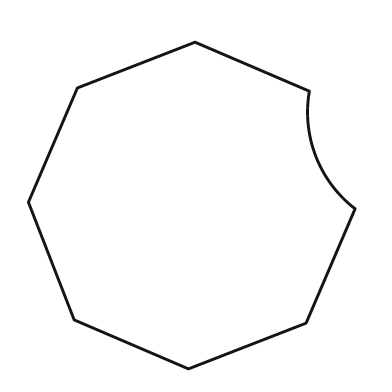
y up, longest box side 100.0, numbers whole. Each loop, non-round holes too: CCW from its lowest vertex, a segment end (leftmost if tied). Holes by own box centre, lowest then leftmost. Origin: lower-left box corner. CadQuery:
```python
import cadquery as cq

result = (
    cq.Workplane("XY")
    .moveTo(49.0, 0.0)
    .lineTo(85.0, 14.0)
    .lineTo(100.0, 49.0)
    .threePointArc((88.0, 65.0), (86.0, 85.0))
    .lineTo(51.0, 100.0)
    .lineTo(15.0, 86.0)
    .lineTo(0.0, 51.0)
    .lineTo(14.0, 15.0)
    .close()
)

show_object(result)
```